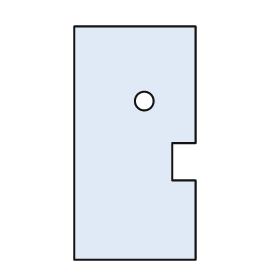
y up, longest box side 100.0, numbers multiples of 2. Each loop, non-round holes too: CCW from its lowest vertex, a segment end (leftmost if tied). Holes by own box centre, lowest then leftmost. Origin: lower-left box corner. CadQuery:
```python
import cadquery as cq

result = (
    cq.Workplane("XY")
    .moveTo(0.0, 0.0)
    .lineTo(52.0, 0.0)
    .lineTo(52.0, 34.0)
    .lineTo(42.0, 34.0)
    .lineTo(42.0, 50.0)
    .lineTo(52.0, 50.0)
    .lineTo(52.0, 100.0)
    .lineTo(0.0, 100.0)
    .close()
    .moveTo(30.0, 68.0)
    .circle(4.0)
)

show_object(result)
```